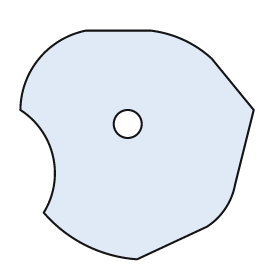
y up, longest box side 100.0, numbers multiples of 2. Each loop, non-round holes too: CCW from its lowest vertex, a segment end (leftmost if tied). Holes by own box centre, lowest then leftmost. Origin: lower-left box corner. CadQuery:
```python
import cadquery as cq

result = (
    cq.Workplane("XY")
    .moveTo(50.0, 0.0)
    .lineTo(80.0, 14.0)
    .threePointArc((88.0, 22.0), (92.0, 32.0))
    .lineTo(100.0, 64.0)
    .lineTo(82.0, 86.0)
    .threePointArc((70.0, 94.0), (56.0, 98.0))
    .lineTo(28.0, 98.0)
    .threePointArc((8.0, 86.0), (0.0, 64.0))
    .threePointArc((14.0, 44.0), (10.0, 20.0))
    .threePointArc((28.0, 6.0), (50.0, 0.0))
    .close()
    .moveTo(46.0, 58.0)
    .circle(6.0)
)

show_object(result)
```